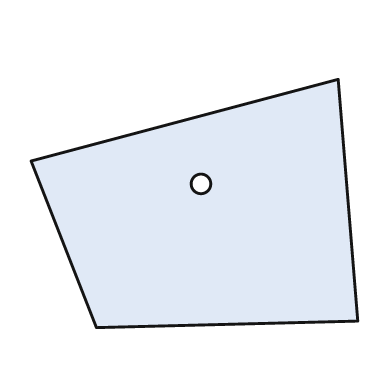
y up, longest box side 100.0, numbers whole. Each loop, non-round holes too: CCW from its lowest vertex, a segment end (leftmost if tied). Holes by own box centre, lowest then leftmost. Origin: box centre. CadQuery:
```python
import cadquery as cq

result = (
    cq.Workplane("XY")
    .moveTo(-30.0, -38.0)
    .lineTo(50.0, -36.0)
    .lineTo(44.0, 38.0)
    .lineTo(-50.0, 13.0)
    .close()
    .moveTo(2.0, 6.0)
    .circle(3.0)
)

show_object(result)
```